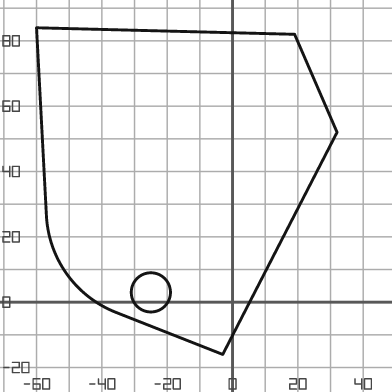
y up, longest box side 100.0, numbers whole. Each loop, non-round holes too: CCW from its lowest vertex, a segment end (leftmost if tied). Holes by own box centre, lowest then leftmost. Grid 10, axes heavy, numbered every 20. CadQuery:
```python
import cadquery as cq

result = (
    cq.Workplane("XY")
    .moveTo(-3.0, -16.0)
    .lineTo(32.0, 52.0)
    .lineTo(19.0, 82.0)
    .lineTo(-60.0, 84.0)
    .lineTo(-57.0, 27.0)
    .threePointArc((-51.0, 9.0), (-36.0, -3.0))
    .close()
    .moveTo(-25.0, 3.0)
    .circle(6.0)
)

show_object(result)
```